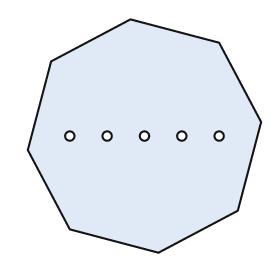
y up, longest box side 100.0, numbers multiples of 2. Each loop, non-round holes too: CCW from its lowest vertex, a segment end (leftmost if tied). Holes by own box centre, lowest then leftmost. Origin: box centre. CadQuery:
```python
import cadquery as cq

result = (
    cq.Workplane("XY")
    .moveTo(6.0, -50.0)
    .lineTo(40.0, -32.0)
    .lineTo(50.0, 6.0)
    .lineTo(32.0, 40.0)
    .lineTo(-6.0, 50.0)
    .lineTo(-40.0, 32.0)
    .lineTo(-50.0, -6.0)
    .lineTo(-32.0, -40.0)
    .close()
    .moveTo(-32.0, 0.0)
    .circle(2.0)
    .moveTo(-16.0, 0.0)
    .circle(2.0)
    .moveTo(0.0, 0.0)
    .circle(2.0)
    .moveTo(16.0, 0.0)
    .circle(2.0)
    .moveTo(32.0, 0.0)
    .circle(2.0)
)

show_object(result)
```